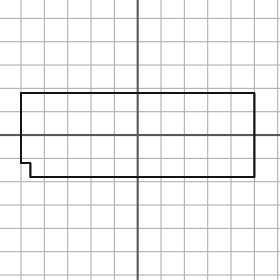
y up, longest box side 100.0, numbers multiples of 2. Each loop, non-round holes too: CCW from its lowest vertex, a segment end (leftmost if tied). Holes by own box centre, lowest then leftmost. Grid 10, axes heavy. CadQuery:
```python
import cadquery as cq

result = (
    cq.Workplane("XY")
    .moveTo(-46.0, -18.0)
    .lineTo(50.0, -18.0)
    .lineTo(50.0, 18.0)
    .lineTo(-50.0, 18.0)
    .lineTo(-50.0, -12.0)
    .lineTo(-46.0, -12.0)
    .close()
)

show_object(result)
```